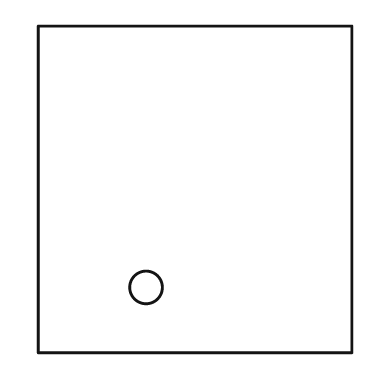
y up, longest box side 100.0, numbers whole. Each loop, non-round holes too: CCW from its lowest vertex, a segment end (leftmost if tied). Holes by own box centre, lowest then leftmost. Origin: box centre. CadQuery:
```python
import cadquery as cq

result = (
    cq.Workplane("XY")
    .moveTo(-48.0, -50.0)
    .lineTo(48.0, -50.0)
    .lineTo(48.0, 50.0)
    .lineTo(-48.0, 50.0)
    .close()
    .moveTo(-15.0, -30.0)
    .circle(5.0)
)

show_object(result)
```